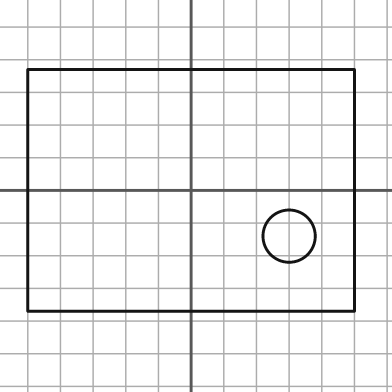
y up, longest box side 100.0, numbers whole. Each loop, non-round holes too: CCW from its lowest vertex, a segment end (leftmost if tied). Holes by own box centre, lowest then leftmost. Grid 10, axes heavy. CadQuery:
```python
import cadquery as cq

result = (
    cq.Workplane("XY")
    .moveTo(-50.0, -37.0)
    .lineTo(50.0, -37.0)
    .lineTo(50.0, 37.0)
    .lineTo(-50.0, 37.0)
    .close()
    .moveTo(30.0, -14.0)
    .circle(8.0)
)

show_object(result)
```